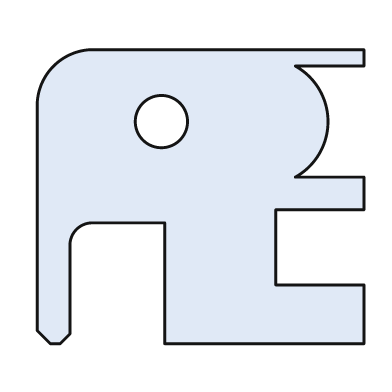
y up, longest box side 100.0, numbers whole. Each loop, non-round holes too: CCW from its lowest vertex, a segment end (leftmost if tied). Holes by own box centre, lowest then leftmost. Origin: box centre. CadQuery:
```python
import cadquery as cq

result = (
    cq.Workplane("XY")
    .moveTo(-46.0, -45.0)
    .lineTo(-43.0, -45.0)
    .lineTo(-40.0, -42.0)
    .lineTo(-40.0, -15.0)
    .threePointArc((-38.0, -10.0), (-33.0, -8.0))
    .lineTo(-11.0, -8.0)
    .lineTo(-11.0, -45.0)
    .lineTo(50.0, -45.0)
    .lineTo(50.0, -27.0)
    .lineTo(23.0, -27.0)
    .lineTo(23.0, -4.0)
    .lineTo(50.0, -4.0)
    .lineTo(50.0, 6.0)
    .lineTo(29.0, 6.0)
    .threePointArc((39.0, 23.0), (29.0, 40.0))
    .lineTo(50.0, 40.0)
    .lineTo(50.0, 45.0)
    .lineTo(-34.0, 45.0)
    .threePointArc((-45.0, 40.0), (-50.0, 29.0))
    .lineTo(-50.0, -41.0)
    .close()
    .moveTo(-12.0, 23.0)
    .circle(8.0)
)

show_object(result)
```